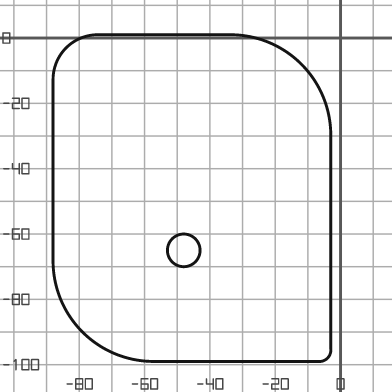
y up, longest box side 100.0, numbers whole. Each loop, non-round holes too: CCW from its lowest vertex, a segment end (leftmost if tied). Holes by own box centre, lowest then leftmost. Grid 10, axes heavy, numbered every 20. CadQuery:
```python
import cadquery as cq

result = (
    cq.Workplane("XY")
    .moveTo(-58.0, -99.0)
    .lineTo(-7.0, -99.0)
    .threePointArc((-4.0, -98.0), (-3.0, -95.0))
    .lineTo(-3.0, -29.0)
    .threePointArc((-12.0, -8.0), (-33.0, 1.0))
    .lineTo(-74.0, 1.0)
    .threePointArc((-84.0, -3.0), (-88.0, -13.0))
    .lineTo(-88.0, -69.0)
    .threePointArc((-79.0, -90.0), (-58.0, -99.0))
    .close()
    .moveTo(-48.0, -65.0)
    .circle(5.0)
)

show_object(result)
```